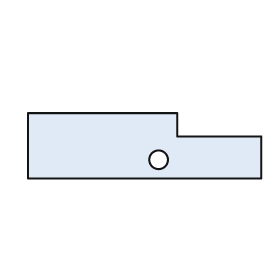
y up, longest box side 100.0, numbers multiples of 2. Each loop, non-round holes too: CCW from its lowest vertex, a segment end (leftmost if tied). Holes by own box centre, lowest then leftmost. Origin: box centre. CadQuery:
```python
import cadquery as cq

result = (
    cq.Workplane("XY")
    .moveTo(-50.0, -14.0)
    .lineTo(50.0, -14.0)
    .lineTo(50.0, 4.0)
    .lineTo(14.0, 4.0)
    .lineTo(14.0, 14.0)
    .lineTo(-50.0, 14.0)
    .close()
    .moveTo(6.0, -6.0)
    .circle(4.0)
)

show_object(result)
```